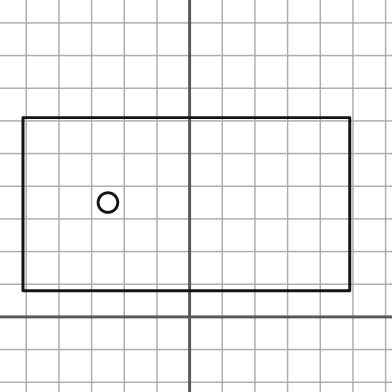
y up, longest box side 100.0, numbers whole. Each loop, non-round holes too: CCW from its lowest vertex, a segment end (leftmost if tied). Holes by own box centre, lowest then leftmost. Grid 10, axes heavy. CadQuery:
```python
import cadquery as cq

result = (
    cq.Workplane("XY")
    .moveTo(-51.0, 8.0)
    .lineTo(49.0, 8.0)
    .lineTo(49.0, 61.0)
    .lineTo(-51.0, 61.0)
    .close()
    .moveTo(-25.0, 35.0)
    .circle(3.0)
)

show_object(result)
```